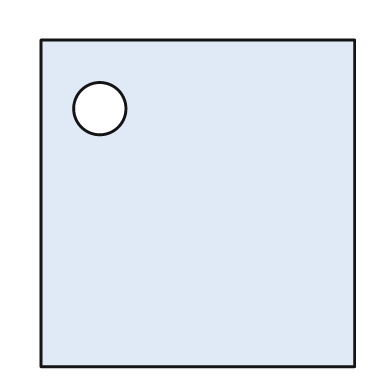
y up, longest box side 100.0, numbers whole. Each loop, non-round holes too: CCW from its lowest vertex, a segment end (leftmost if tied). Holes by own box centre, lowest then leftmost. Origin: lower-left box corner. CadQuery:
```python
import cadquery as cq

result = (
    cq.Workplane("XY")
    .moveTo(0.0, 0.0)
    .lineTo(96.0, 0.0)
    .lineTo(96.0, 100.0)
    .lineTo(0.0, 100.0)
    .close()
    .moveTo(18.0, 79.0)
    .circle(8.0)
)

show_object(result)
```